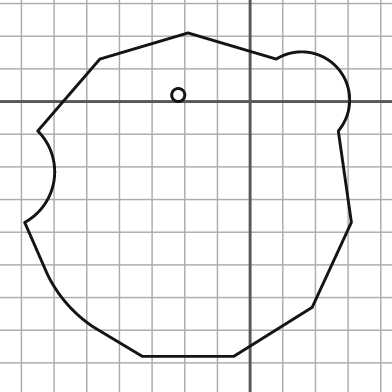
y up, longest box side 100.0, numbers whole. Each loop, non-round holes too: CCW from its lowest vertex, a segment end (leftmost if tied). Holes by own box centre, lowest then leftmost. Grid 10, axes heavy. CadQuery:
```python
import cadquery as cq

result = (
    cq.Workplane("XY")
    .moveTo(-33.0, -78.0)
    .lineTo(-5.0, -78.0)
    .lineTo(19.0, -63.0)
    .lineTo(31.0, -37.0)
    .lineTo(27.0, -9.0)
    .threePointArc((27.0, 10.0), (8.0, 13.0))
    .lineTo(-19.0, 21.0)
    .lineTo(-46.0, 13.0)
    .lineTo(-65.0, -9.0)
    .threePointArc((-60.0, -24.0), (-69.0, -37.0))
    .lineTo(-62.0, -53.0)
    .threePointArc((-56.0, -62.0), (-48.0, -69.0))
    .close()
    .moveTo(-22.0, 2.0)
    .circle(2.0)
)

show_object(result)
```